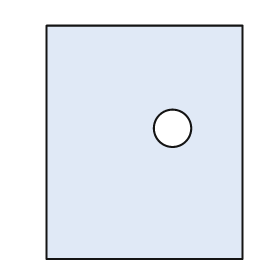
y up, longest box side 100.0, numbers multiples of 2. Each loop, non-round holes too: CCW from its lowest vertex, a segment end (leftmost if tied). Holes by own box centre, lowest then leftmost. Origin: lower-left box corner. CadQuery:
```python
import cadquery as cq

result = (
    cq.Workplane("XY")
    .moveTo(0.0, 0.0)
    .lineTo(84.0, 0.0)
    .lineTo(84.0, 100.0)
    .lineTo(0.0, 100.0)
    .close()
    .moveTo(54.0, 56.0)
    .circle(8.0)
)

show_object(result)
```